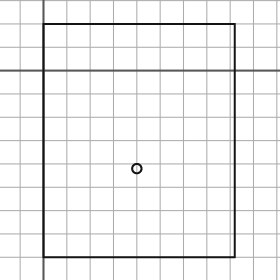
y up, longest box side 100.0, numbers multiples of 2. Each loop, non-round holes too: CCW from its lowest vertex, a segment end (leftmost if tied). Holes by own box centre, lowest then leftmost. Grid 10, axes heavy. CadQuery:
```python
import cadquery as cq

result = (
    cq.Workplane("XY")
    .moveTo(0.0, -80.0)
    .lineTo(82.0, -80.0)
    .lineTo(82.0, 20.0)
    .lineTo(0.0, 20.0)
    .close()
    .moveTo(40.0, -42.0)
    .circle(2.0)
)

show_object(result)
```